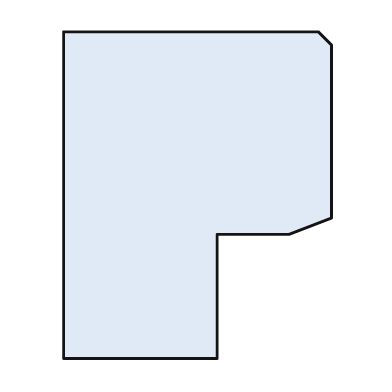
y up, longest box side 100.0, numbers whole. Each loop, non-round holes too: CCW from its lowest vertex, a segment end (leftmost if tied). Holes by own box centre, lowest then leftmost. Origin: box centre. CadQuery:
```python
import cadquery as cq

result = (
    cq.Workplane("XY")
    .moveTo(-41.0, -50.0)
    .lineTo(6.0, -50.0)
    .lineTo(6.0, -12.0)
    .lineTo(28.0, -12.0)
    .lineTo(41.0, -7.0)
    .lineTo(41.0, 46.0)
    .lineTo(37.0, 50.0)
    .lineTo(-41.0, 50.0)
    .close()
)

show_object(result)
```